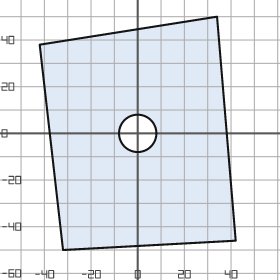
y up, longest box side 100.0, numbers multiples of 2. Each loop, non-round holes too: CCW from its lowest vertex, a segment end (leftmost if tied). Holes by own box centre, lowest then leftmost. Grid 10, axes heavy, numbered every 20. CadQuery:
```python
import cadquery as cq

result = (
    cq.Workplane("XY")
    .moveTo(-32.0, -50.0)
    .lineTo(42.0, -46.0)
    .lineTo(34.0, 50.0)
    .lineTo(-42.0, 38.0)
    .close()
    .moveTo(0.0, 0.0)
    .circle(8.0)
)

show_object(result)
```